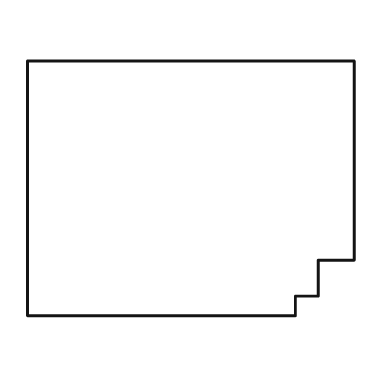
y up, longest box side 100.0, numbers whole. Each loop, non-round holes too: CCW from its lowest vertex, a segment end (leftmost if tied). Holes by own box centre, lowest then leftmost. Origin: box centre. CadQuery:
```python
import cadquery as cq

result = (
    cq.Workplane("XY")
    .moveTo(-50.0, -39.0)
    .lineTo(32.0, -39.0)
    .lineTo(32.0, -33.0)
    .lineTo(39.0, -33.0)
    .lineTo(39.0, -22.0)
    .lineTo(50.0, -22.0)
    .lineTo(50.0, 39.0)
    .lineTo(-50.0, 39.0)
    .close()
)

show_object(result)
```